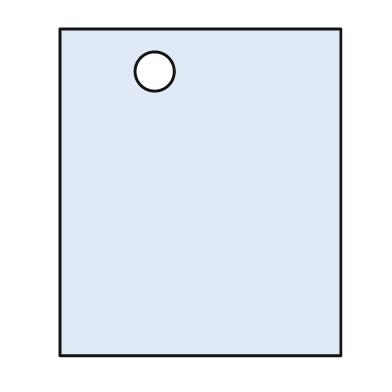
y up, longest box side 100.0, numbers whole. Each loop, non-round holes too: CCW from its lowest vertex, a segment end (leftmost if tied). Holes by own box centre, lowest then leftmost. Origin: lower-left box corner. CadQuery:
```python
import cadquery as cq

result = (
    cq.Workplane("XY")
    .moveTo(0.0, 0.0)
    .lineTo(86.0, 0.0)
    .lineTo(86.0, 100.0)
    .lineTo(0.0, 100.0)
    .close()
    .moveTo(29.0, 87.0)
    .circle(6.0)
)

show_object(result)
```